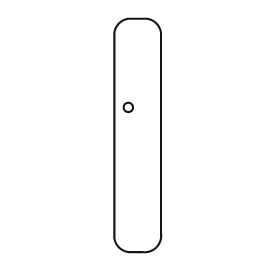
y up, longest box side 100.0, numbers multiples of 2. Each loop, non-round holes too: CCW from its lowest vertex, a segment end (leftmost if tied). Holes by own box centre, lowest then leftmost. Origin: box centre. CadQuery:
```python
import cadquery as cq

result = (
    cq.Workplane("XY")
    .moveTo(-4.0, -50.0)
    .lineTo(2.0, -50.0)
    .threePointArc((8.0, -48.0), (10.0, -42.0))
    .lineTo(10.0, 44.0)
    .threePointArc((8.0, 48.0), (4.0, 50.0))
    .lineTo(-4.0, 50.0)
    .threePointArc((-8.0, 48.0), (-10.0, 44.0))
    .lineTo(-10.0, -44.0)
    .threePointArc((-8.0, -48.0), (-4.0, -50.0))
    .close()
    .moveTo(-4.0, 12.0)
    .circle(2.0)
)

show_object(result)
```